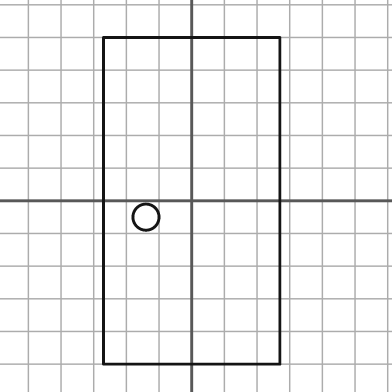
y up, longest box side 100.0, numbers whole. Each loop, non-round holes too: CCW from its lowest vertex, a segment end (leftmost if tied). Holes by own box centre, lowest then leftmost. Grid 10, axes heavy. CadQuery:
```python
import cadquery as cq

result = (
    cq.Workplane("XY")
    .moveTo(-27.0, -50.0)
    .lineTo(27.0, -50.0)
    .lineTo(27.0, 50.0)
    .lineTo(-27.0, 50.0)
    .close()
    .moveTo(-14.0, -5.0)
    .circle(4.0)
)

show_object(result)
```